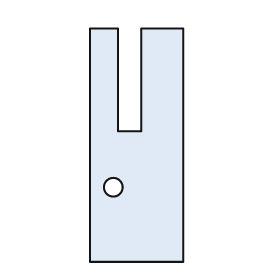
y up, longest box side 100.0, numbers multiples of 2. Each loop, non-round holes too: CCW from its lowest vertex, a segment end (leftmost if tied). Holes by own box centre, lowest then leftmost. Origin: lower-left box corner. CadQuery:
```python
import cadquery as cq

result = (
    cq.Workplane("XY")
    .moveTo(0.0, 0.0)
    .lineTo(40.0, 0.0)
    .lineTo(40.0, 100.0)
    .lineTo(22.0, 100.0)
    .lineTo(22.0, 56.0)
    .lineTo(12.0, 56.0)
    .lineTo(12.0, 100.0)
    .lineTo(0.0, 100.0)
    .close()
    .moveTo(10.0, 32.0)
    .circle(4.0)
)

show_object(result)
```